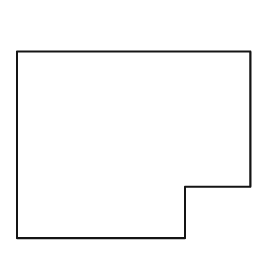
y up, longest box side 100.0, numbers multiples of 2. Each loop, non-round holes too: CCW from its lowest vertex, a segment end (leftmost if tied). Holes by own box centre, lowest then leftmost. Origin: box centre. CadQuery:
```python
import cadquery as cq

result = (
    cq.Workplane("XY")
    .moveTo(-50.0, -40.0)
    .lineTo(22.0, -40.0)
    .lineTo(22.0, -18.0)
    .lineTo(50.0, -18.0)
    .lineTo(50.0, 40.0)
    .lineTo(-50.0, 40.0)
    .close()
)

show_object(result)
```